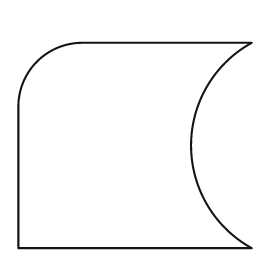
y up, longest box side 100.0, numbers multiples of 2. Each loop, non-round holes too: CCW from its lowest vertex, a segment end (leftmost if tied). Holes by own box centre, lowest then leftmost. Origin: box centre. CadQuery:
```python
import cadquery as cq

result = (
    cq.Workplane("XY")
    .moveTo(-50.0, -44.0)
    .lineTo(50.0, -44.0)
    .threePointArc((24.0, 0.0), (50.0, 44.0))
    .lineTo(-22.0, 44.0)
    .threePointArc((-42.0, 36.0), (-50.0, 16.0))
    .close()
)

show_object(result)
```